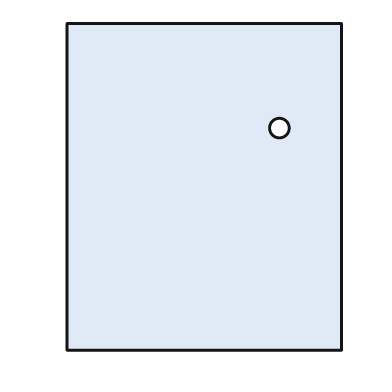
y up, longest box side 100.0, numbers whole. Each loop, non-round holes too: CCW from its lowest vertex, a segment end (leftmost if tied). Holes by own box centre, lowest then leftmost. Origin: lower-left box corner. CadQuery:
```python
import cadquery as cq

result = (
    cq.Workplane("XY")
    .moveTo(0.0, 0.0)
    .lineTo(84.0, 0.0)
    .lineTo(84.0, 100.0)
    .lineTo(0.0, 100.0)
    .close()
    .moveTo(65.0, 68.0)
    .circle(3.0)
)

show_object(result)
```